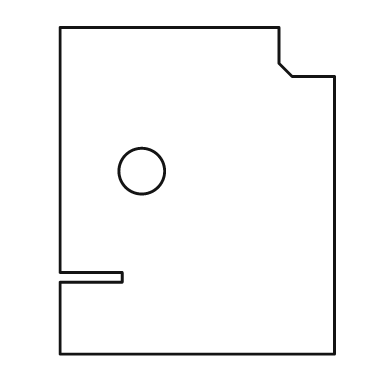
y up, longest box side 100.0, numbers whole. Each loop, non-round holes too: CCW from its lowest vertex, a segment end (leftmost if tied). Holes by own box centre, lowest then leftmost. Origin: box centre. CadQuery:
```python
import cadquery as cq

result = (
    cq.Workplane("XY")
    .moveTo(-42.0, -50.0)
    .lineTo(42.0, -50.0)
    .lineTo(42.0, 35.0)
    .lineTo(29.0, 35.0)
    .lineTo(25.0, 39.0)
    .lineTo(25.0, 50.0)
    .lineTo(-42.0, 50.0)
    .lineTo(-42.0, -25.0)
    .lineTo(-23.0, -25.0)
    .lineTo(-23.0, -28.0)
    .lineTo(-42.0, -28.0)
    .close()
    .moveTo(-17.0, 6.0)
    .circle(7.0)
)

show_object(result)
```